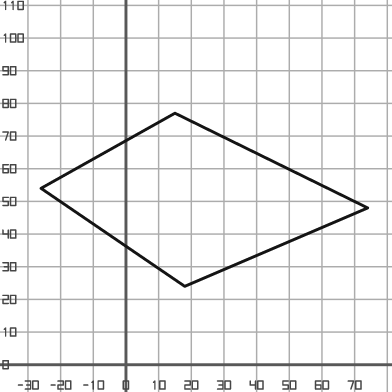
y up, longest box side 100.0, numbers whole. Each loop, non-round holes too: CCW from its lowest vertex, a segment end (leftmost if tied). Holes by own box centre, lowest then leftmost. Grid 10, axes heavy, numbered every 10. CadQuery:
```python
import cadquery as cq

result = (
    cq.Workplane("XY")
    .moveTo(18.0, 24.0)
    .lineTo(74.0, 48.0)
    .lineTo(15.0, 77.0)
    .lineTo(-26.0, 54.0)
    .close()
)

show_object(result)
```